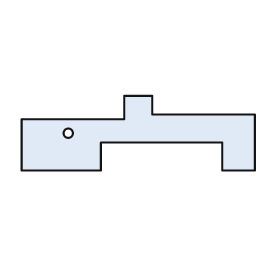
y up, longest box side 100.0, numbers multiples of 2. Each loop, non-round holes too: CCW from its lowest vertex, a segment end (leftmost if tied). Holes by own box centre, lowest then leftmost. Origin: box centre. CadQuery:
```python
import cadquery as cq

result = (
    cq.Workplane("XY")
    .moveTo(-50.0, -16.0)
    .lineTo(-16.0, -16.0)
    .lineTo(-16.0, -4.0)
    .lineTo(36.0, -4.0)
    .lineTo(36.0, -16.0)
    .lineTo(50.0, -16.0)
    .lineTo(50.0, 8.0)
    .lineTo(6.0, 8.0)
    .lineTo(6.0, 16.0)
    .lineTo(-6.0, 16.0)
    .lineTo(-6.0, 6.0)
    .lineTo(-50.0, 6.0)
    .close()
    .moveTo(-30.0, 0.0)
    .circle(2.0)
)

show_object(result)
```